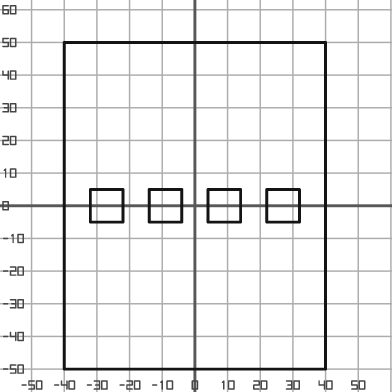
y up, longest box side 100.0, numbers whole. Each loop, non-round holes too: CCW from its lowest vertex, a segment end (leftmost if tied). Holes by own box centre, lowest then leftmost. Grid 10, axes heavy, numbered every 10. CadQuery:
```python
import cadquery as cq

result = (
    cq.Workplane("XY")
    .moveTo(-40.0, -50.0)
    .lineTo(40.0, -50.0)
    .lineTo(40.0, 50.0)
    .lineTo(-40.0, 50.0)
    .close()
    .moveTo(-32.0, -5.0)
    .lineTo(-22.0, -5.0)
    .lineTo(-22.0, 5.0)
    .lineTo(-32.0, 5.0)
    .close()
    .moveTo(-14.0, -5.0)
    .lineTo(-4.0, -5.0)
    .lineTo(-4.0, 5.0)
    .lineTo(-14.0, 5.0)
    .close()
    .moveTo(4.0, -5.0)
    .lineTo(14.0, -5.0)
    .lineTo(14.0, 5.0)
    .lineTo(4.0, 5.0)
    .close()
    .moveTo(22.0, -5.0)
    .lineTo(32.0, -5.0)
    .lineTo(32.0, 5.0)
    .lineTo(22.0, 5.0)
    .close()
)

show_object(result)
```